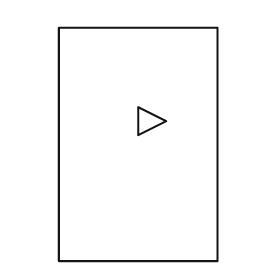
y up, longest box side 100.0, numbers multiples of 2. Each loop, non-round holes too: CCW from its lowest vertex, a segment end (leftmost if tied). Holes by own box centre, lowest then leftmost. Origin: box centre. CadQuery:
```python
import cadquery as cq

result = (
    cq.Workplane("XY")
    .moveTo(-34.0, -50.0)
    .lineTo(34.0, -50.0)
    .lineTo(34.0, 50.0)
    .lineTo(-34.0, 50.0)
    .close()
    .moveTo(0.0, 4.0)
    .lineTo(12.0, 10.0)
    .lineTo(0.0, 16.0)
    .close()
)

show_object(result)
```